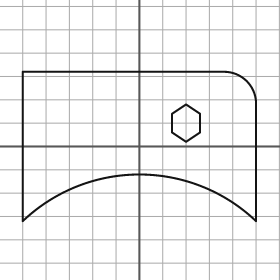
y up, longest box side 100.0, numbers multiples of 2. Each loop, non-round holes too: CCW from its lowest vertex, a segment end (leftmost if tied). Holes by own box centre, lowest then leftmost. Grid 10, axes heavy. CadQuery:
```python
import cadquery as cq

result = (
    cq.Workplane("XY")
    .moveTo(-50.0, -32.0)
    .threePointArc((0.0, -12.0), (50.0, -32.0))
    .lineTo(50.0, 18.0)
    .threePointArc((46.0, 28.0), (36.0, 32.0))
    .lineTo(-50.0, 32.0)
    .close()
    .moveTo(20.0, 2.0)
    .lineTo(26.0, 6.0)
    .lineTo(26.0, 14.0)
    .lineTo(20.0, 18.0)
    .lineTo(14.0, 14.0)
    .lineTo(14.0, 6.0)
    .close()
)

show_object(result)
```